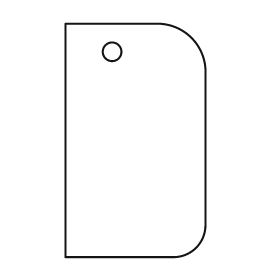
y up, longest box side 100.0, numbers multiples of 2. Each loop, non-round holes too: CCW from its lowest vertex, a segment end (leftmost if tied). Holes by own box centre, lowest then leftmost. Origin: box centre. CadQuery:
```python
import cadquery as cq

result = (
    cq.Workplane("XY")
    .moveTo(-30.0, -50.0)
    .lineTo(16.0, -50.0)
    .threePointArc((26.0, -46.0), (30.0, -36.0))
    .lineTo(30.0, 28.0)
    .threePointArc((24.0, 44.0), (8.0, 50.0))
    .lineTo(-30.0, 50.0)
    .close()
    .moveTo(-10.0, 38.0)
    .circle(4.0)
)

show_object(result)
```